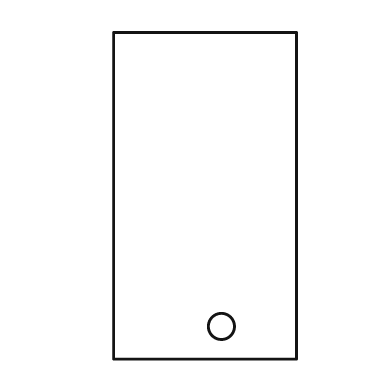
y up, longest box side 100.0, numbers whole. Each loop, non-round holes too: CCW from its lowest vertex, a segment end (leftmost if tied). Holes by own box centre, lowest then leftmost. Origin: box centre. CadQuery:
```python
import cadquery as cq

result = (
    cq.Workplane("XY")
    .moveTo(-28.0, -50.0)
    .lineTo(28.0, -50.0)
    .lineTo(28.0, 50.0)
    .lineTo(-28.0, 50.0)
    .close()
    .moveTo(5.0, -40.0)
    .circle(4.0)
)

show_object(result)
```